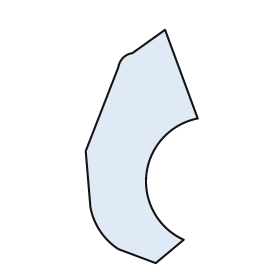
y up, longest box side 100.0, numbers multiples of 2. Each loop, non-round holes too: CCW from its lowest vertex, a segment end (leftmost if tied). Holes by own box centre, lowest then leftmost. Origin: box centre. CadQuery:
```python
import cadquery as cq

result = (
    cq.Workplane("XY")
    .moveTo(6.0, -50.0)
    .lineTo(18.0, -40.0)
    .threePointArc((2.0, -12.0), (24.0, 12.0))
    .lineTo(10.0, 50.0)
    .lineTo(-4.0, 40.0)
    .threePointArc((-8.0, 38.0), (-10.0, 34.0))
    .lineTo(-24.0, -2.0)
    .lineTo(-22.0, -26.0)
    .threePointArc((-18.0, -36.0), (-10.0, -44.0))
    .close()
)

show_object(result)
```